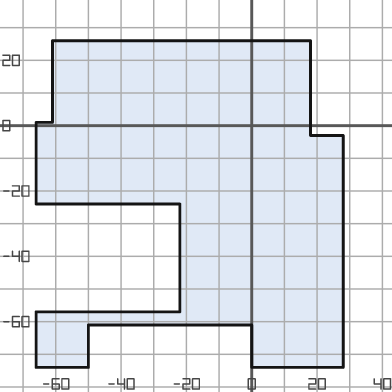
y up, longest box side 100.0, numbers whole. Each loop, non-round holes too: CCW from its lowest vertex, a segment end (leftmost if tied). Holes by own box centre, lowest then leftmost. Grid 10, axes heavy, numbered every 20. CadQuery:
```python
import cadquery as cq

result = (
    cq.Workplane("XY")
    .moveTo(-66.0, -74.0)
    .lineTo(-50.0, -74.0)
    .lineTo(-50.0, -61.0)
    .lineTo(0.0, -61.0)
    .lineTo(0.0, -74.0)
    .lineTo(28.0, -74.0)
    .lineTo(28.0, -3.0)
    .lineTo(18.0, -3.0)
    .lineTo(18.0, 26.0)
    .lineTo(-61.0, 26.0)
    .lineTo(-61.0, 1.0)
    .lineTo(-66.0, 1.0)
    .lineTo(-66.0, -24.0)
    .lineTo(-22.0, -24.0)
    .lineTo(-22.0, -57.0)
    .lineTo(-66.0, -57.0)
    .close()
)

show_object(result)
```